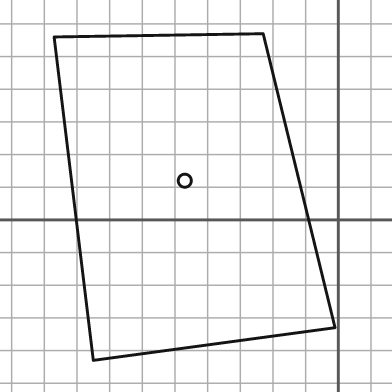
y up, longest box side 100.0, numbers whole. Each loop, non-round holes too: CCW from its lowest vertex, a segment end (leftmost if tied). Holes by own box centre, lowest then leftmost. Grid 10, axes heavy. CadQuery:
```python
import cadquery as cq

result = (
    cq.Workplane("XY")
    .moveTo(-75.0, -43.0)
    .lineTo(-1.0, -33.0)
    .lineTo(-23.0, 57.0)
    .lineTo(-87.0, 56.0)
    .close()
    .moveTo(-47.0, 12.0)
    .circle(2.0)
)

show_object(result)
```